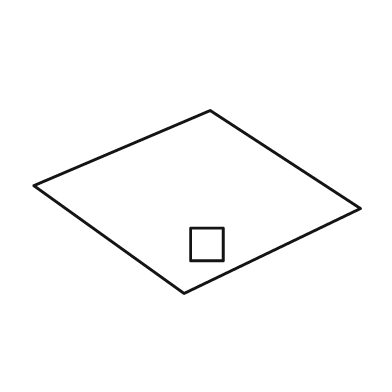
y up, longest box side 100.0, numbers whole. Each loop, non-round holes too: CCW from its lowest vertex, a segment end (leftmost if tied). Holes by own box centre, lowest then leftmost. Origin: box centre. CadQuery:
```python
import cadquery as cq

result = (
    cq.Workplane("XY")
    .moveTo(-4.0, -28.0)
    .lineTo(50.0, -2.0)
    .lineTo(4.0, 28.0)
    .lineTo(-50.0, 5.0)
    .close()
    .moveTo(-2.0, -18.0)
    .lineTo(8.0, -18.0)
    .lineTo(8.0, -8.0)
    .lineTo(-2.0, -8.0)
    .close()
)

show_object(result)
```